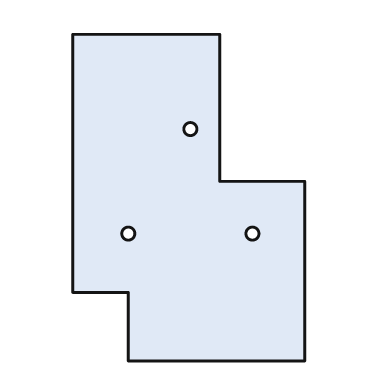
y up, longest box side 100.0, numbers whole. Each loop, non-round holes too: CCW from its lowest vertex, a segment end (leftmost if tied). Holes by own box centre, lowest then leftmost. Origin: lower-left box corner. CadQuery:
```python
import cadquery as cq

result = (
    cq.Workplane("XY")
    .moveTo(17.0, 0.0)
    .lineTo(71.0, 0.0)
    .lineTo(71.0, 55.0)
    .lineTo(45.0, 55.0)
    .lineTo(45.0, 100.0)
    .lineTo(0.0, 100.0)
    .lineTo(0.0, 21.0)
    .lineTo(17.0, 21.0)
    .close()
    .moveTo(17.0, 39.0)
    .circle(2.0)
    .moveTo(55.0, 39.0)
    .circle(2.0)
    .moveTo(36.0, 71.0)
    .circle(2.0)
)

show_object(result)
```